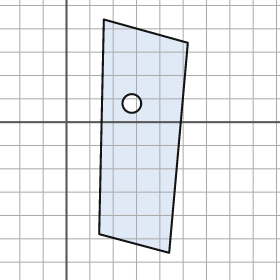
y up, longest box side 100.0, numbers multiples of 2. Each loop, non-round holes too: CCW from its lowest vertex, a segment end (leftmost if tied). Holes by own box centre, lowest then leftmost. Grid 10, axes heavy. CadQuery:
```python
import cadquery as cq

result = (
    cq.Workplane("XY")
    .moveTo(44.0, -56.0)
    .lineTo(52.0, 34.0)
    .lineTo(16.0, 44.0)
    .lineTo(14.0, -48.0)
    .close()
    .moveTo(28.0, 8.0)
    .circle(4.0)
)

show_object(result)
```